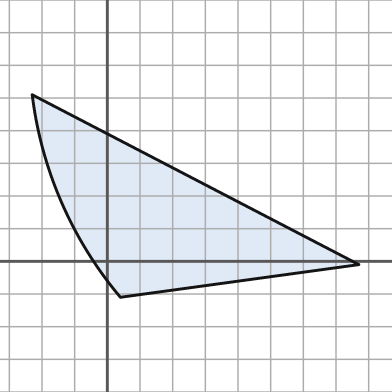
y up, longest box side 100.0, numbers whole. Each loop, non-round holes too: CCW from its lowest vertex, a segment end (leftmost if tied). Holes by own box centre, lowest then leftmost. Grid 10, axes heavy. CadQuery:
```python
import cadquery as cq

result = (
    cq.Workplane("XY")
    .moveTo(4.0, -11.0)
    .lineTo(77.0, -1.0)
    .lineTo(-23.0, 51.0)
    .threePointArc((-14.0, 18.0), (4.0, -11.0))
    .close()
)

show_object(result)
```